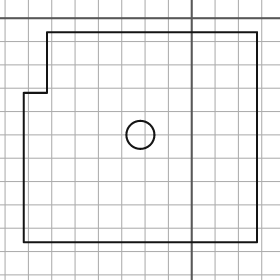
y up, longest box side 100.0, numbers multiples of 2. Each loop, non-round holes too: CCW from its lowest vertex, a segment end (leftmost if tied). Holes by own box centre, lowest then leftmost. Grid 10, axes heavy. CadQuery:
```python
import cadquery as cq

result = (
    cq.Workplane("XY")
    .moveTo(-72.0, -96.0)
    .lineTo(28.0, -96.0)
    .lineTo(28.0, -6.0)
    .lineTo(-62.0, -6.0)
    .lineTo(-62.0, -32.0)
    .lineTo(-72.0, -32.0)
    .close()
    .moveTo(-22.0, -50.0)
    .circle(6.0)
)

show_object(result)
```